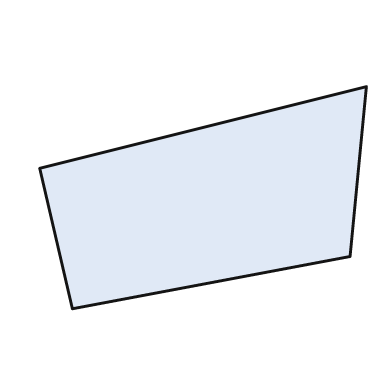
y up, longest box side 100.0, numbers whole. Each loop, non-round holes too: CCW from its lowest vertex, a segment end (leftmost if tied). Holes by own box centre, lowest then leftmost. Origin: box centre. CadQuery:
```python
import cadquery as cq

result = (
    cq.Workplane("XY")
    .moveTo(-40.0, -34.0)
    .lineTo(45.0, -18.0)
    .lineTo(50.0, 34.0)
    .lineTo(-50.0, 9.0)
    .close()
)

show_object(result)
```